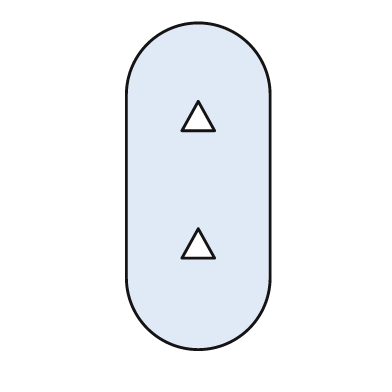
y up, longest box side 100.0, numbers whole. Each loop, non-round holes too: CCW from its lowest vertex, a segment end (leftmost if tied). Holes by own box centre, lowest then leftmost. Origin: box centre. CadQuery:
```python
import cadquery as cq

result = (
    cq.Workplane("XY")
    .moveTo(-22.0, -28.0)
    .threePointArc((0.0, -50.0), (22.0, -28.0))
    .lineTo(22.0, 28.0)
    .threePointArc((0.0, 50.0), (-22.0, 28.0))
    .close()
    .moveTo(-5.0, -22.0)
    .lineTo(5.0, -22.0)
    .lineTo(0.0, -13.0)
    .close()
    .moveTo(-5.0, 17.0)
    .lineTo(5.0, 17.0)
    .lineTo(0.0, 26.0)
    .close()
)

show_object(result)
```